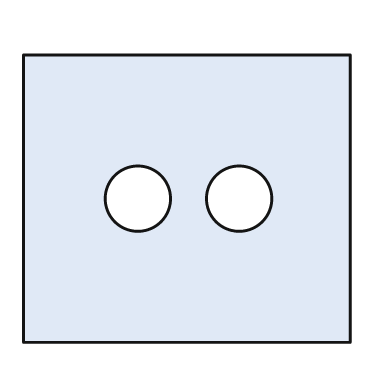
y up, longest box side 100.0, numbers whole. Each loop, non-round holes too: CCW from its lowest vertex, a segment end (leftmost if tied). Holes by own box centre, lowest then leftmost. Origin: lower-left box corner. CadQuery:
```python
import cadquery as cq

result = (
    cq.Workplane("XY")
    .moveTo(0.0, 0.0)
    .lineTo(100.0, 0.0)
    .lineTo(100.0, 88.0)
    .lineTo(0.0, 88.0)
    .close()
    .moveTo(35.0, 44.0)
    .circle(10.0)
    .moveTo(66.0, 44.0)
    .circle(10.0)
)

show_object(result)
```